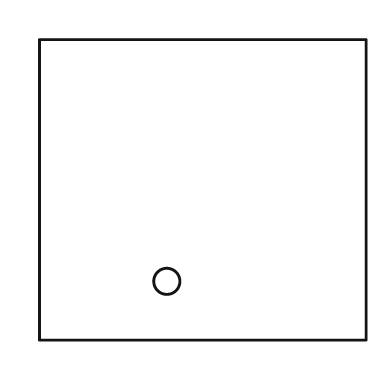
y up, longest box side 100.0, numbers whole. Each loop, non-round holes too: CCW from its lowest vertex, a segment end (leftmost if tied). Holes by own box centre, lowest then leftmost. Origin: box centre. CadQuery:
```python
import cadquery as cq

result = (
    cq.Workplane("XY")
    .moveTo(-50.0, -46.0)
    .lineTo(50.0, -46.0)
    .lineTo(50.0, 46.0)
    .lineTo(-50.0, 46.0)
    .close()
    .moveTo(-11.0, -28.0)
    .circle(4.0)
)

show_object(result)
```